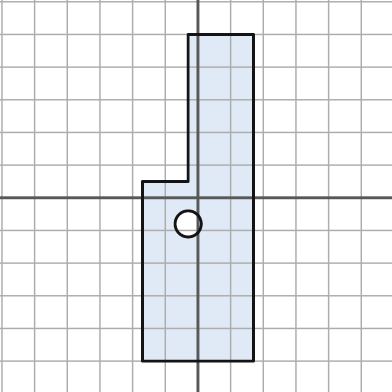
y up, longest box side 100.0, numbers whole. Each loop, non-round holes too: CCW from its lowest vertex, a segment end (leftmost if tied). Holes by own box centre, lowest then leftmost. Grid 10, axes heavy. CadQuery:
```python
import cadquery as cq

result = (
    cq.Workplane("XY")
    .moveTo(-17.0, -50.0)
    .lineTo(17.0, -50.0)
    .lineTo(17.0, 50.0)
    .lineTo(-3.0, 50.0)
    .lineTo(-3.0, 5.0)
    .lineTo(-17.0, 5.0)
    .close()
    .moveTo(-3.0, -8.0)
    .circle(4.0)
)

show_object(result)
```